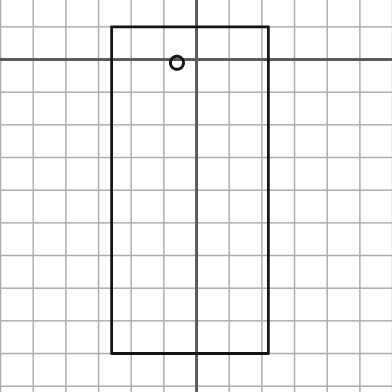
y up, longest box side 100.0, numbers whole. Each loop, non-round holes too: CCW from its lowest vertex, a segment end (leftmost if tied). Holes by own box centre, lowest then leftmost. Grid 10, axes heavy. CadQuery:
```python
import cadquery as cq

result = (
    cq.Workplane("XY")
    .moveTo(-26.0, -90.0)
    .lineTo(22.0, -90.0)
    .lineTo(22.0, 10.0)
    .lineTo(-26.0, 10.0)
    .close()
    .moveTo(-6.0, -1.0)
    .circle(2.0)
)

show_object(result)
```